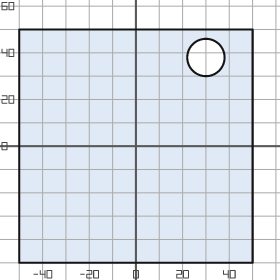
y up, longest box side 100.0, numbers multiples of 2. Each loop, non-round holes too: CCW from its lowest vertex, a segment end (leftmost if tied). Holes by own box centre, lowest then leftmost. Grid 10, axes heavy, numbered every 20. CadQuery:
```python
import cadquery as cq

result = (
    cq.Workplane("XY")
    .moveTo(-50.0, -50.0)
    .lineTo(50.0, -50.0)
    .lineTo(50.0, 50.0)
    .lineTo(-50.0, 50.0)
    .close()
    .moveTo(30.0, 38.0)
    .circle(8.0)
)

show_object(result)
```